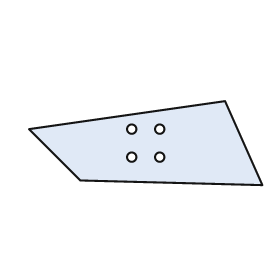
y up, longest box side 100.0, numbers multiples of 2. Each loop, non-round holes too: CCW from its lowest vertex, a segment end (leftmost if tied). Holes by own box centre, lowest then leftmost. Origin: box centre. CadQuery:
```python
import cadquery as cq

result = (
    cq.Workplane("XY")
    .moveTo(50.0, -18.0)
    .lineTo(34.0, 18.0)
    .lineTo(-50.0, 6.0)
    .lineTo(-28.0, -16.0)
    .close()
    .moveTo(-6.0, -6.0)
    .circle(2.0)
    .moveTo(6.0, -6.0)
    .circle(2.0)
    .moveTo(-6.0, 6.0)
    .circle(2.0)
    .moveTo(6.0, 6.0)
    .circle(2.0)
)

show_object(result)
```